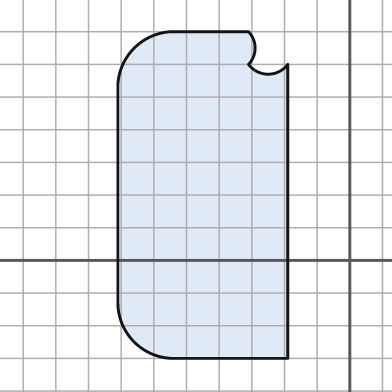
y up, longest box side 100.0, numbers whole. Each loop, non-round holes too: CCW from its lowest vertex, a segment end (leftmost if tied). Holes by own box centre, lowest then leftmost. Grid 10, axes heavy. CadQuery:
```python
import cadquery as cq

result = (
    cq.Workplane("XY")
    .moveTo(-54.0, -30.0)
    .lineTo(-19.0, -30.0)
    .lineTo(-19.0, 60.0)
    .threePointArc((-25.0, 57.0), (-31.0, 60.0))
    .threePointArc((-29.0, 65.0), (-31.0, 70.0))
    .lineTo(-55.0, 70.0)
    .threePointArc((-66.0, 65.0), (-71.0, 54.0))
    .lineTo(-71.0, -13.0)
    .threePointArc((-66.0, -25.0), (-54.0, -30.0))
    .close()
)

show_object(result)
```